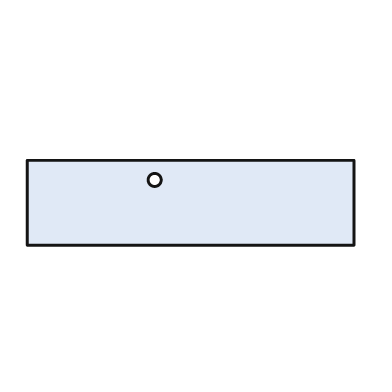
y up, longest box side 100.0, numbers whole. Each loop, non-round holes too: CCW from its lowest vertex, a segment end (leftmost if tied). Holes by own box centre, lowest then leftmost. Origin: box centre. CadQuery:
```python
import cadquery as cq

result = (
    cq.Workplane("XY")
    .moveTo(-50.0, -13.0)
    .lineTo(50.0, -13.0)
    .lineTo(50.0, 13.0)
    .lineTo(-50.0, 13.0)
    .close()
    .moveTo(-11.0, 7.0)
    .circle(2.0)
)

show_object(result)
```